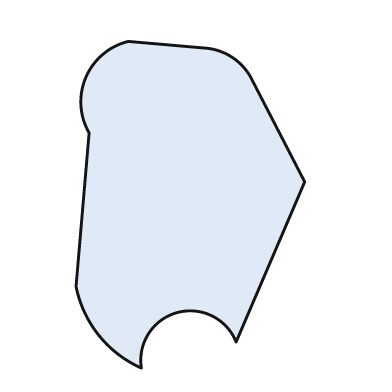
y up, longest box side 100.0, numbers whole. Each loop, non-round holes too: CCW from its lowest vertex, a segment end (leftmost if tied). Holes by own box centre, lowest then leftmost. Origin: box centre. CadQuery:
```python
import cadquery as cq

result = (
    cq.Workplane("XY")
    .moveTo(-15.0, -50.0)
    .threePointArc((-4.0, -33.0), (14.0, -42.0))
    .lineTo(35.0, 7.0)
    .lineTo(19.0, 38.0)
    .threePointArc((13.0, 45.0), (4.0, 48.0))
    .lineTo(-19.0, 50.0)
    .threePointArc((-32.0, 39.0), (-31.0, 22.0))
    .lineTo(-35.0, -25.0)
    .threePointArc((-28.0, -40.0), (-15.0, -50.0))
    .close()
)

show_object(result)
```